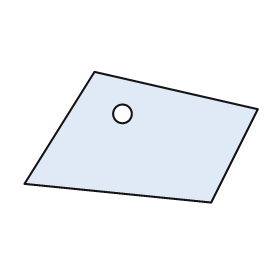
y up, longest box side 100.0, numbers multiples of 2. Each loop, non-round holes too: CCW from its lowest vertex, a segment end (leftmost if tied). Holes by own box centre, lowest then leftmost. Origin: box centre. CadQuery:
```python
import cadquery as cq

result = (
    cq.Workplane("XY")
    .moveTo(30.0, -28.0)
    .lineTo(50.0, 12.0)
    .lineTo(-20.0, 28.0)
    .lineTo(-50.0, -20.0)
    .close()
    .moveTo(-8.0, 10.0)
    .circle(4.0)
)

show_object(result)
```